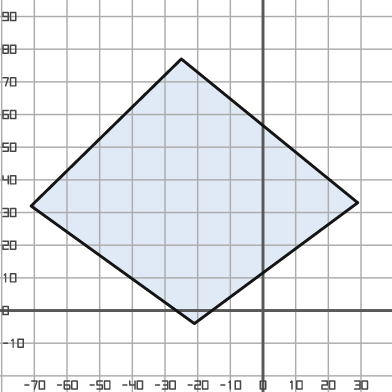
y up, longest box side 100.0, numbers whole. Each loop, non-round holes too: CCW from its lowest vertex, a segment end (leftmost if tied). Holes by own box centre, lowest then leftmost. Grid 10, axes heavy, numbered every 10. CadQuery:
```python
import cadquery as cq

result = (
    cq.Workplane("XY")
    .moveTo(-21.0, -4.0)
    .lineTo(29.0, 33.0)
    .lineTo(-25.0, 77.0)
    .lineTo(-71.0, 32.0)
    .close()
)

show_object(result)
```